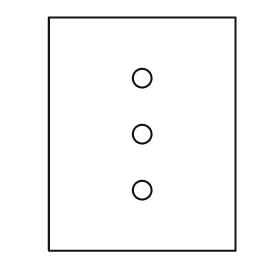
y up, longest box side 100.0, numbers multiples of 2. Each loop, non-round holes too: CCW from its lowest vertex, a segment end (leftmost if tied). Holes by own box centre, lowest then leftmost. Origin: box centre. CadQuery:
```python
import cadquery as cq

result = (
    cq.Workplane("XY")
    .moveTo(-40.0, -50.0)
    .lineTo(40.0, -50.0)
    .lineTo(40.0, 50.0)
    .lineTo(-40.0, 50.0)
    .close()
    .moveTo(0.0, -24.0)
    .circle(4.0)
    .moveTo(0.0, 0.0)
    .circle(4.0)
    .moveTo(0.0, 24.0)
    .circle(4.0)
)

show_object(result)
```